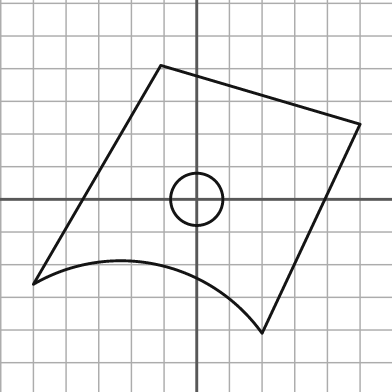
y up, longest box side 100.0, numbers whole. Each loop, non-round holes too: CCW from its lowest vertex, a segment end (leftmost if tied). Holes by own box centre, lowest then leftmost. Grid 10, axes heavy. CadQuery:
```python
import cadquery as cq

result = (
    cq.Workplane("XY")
    .moveTo(20.0, -41.0)
    .lineTo(50.0, 23.0)
    .lineTo(-11.0, 41.0)
    .lineTo(-50.0, -26.0)
    .threePointArc((-12.0, -20.0), (20.0, -41.0))
    .close()
    .moveTo(0.0, 0.0)
    .circle(8.0)
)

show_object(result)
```